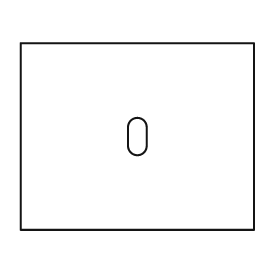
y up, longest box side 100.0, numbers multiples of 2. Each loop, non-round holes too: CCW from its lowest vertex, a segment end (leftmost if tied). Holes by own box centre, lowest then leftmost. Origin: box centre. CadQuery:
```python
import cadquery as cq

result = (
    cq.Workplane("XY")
    .moveTo(-50.0, -40.0)
    .lineTo(50.0, -40.0)
    .lineTo(50.0, 40.0)
    .lineTo(-50.0, 40.0)
    .close()
    .moveTo(-4.0, -4.0)
    .threePointArc((0.0, -8.0), (4.0, -4.0))
    .lineTo(4.0, 4.0)
    .threePointArc((0.0, 8.0), (-4.0, 4.0))
    .close()
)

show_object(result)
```